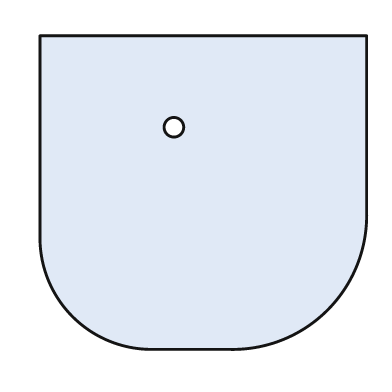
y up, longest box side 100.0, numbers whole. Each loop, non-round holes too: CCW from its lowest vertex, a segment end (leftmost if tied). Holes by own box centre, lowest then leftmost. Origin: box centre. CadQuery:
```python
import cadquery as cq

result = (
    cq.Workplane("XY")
    .moveTo(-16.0, -48.0)
    .lineTo(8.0, -48.0)
    .threePointArc((38.0, -36.0), (50.0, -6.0))
    .lineTo(50.0, 48.0)
    .lineTo(-50.0, 48.0)
    .lineTo(-50.0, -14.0)
    .threePointArc((-40.0, -38.0), (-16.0, -48.0))
    .close()
    .moveTo(-9.0, 20.0)
    .circle(3.0)
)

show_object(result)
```